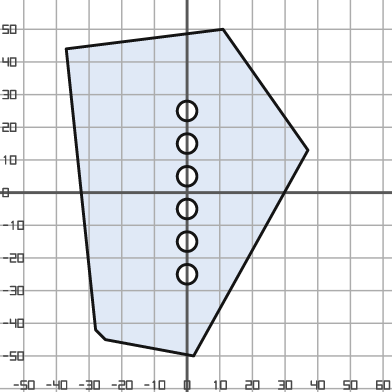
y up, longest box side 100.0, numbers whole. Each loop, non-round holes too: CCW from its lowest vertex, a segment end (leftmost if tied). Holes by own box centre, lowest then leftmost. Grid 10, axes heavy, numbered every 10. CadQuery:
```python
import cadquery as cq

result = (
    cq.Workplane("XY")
    .moveTo(2.0, -50.0)
    .lineTo(37.0, 13.0)
    .lineTo(11.0, 50.0)
    .lineTo(-37.0, 44.0)
    .lineTo(-28.0, -42.0)
    .lineTo(-25.0, -45.0)
    .close()
    .moveTo(0.0, -25.0)
    .circle(3.0)
    .moveTo(0.0, -15.0)
    .circle(3.0)
    .moveTo(0.0, -5.0)
    .circle(3.0)
    .moveTo(0.0, 5.0)
    .circle(3.0)
    .moveTo(0.0, 15.0)
    .circle(3.0)
    .moveTo(0.0, 25.0)
    .circle(3.0)
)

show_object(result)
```